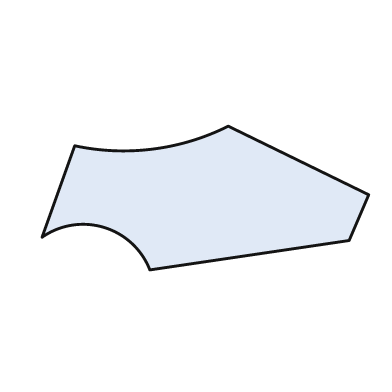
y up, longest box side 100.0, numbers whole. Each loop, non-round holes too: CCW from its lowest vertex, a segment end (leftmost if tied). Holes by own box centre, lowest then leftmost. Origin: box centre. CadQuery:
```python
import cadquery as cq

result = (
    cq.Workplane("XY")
    .moveTo(-17.0, -22.0)
    .lineTo(44.0, -13.0)
    .lineTo(50.0, 1.0)
    .lineTo(7.0, 22.0)
    .threePointArc((-16.0, 15.0), (-40.0, 16.0))
    .lineTo(-50.0, -12.0)
    .threePointArc((-31.0, -9.0), (-17.0, -22.0))
    .close()
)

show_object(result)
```